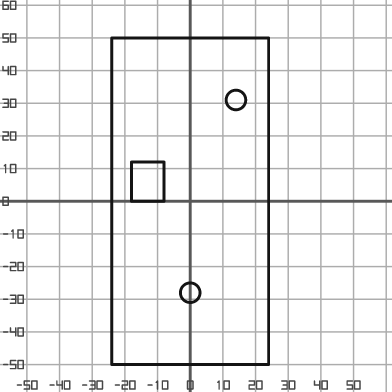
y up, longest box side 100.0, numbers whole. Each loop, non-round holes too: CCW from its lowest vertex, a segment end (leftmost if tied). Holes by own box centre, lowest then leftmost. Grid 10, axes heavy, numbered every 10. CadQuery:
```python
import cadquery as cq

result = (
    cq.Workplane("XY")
    .moveTo(-24.0, -50.0)
    .lineTo(24.0, -50.0)
    .lineTo(24.0, 50.0)
    .lineTo(-24.0, 50.0)
    .close()
    .moveTo(0.0, -28.0)
    .circle(3.0)
    .moveTo(-18.0, 0.0)
    .lineTo(-8.0, 0.0)
    .lineTo(-8.0, 12.0)
    .lineTo(-18.0, 12.0)
    .close()
    .moveTo(14.0, 31.0)
    .circle(3.0)
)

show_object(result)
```